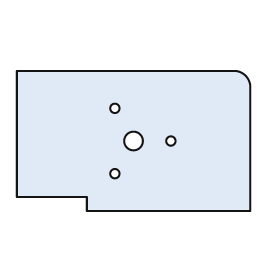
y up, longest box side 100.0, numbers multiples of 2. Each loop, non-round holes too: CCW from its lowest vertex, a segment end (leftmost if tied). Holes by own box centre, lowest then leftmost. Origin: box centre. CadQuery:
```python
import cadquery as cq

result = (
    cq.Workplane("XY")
    .moveTo(-20.0, -30.0)
    .lineTo(50.0, -30.0)
    .lineTo(50.0, 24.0)
    .threePointArc((48.0, 28.0), (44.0, 30.0))
    .lineTo(-50.0, 30.0)
    .lineTo(-50.0, -24.0)
    .lineTo(-20.0, -24.0)
    .close()
    .moveTo(-8.0, -14.0)
    .circle(2.0)
    .moveTo(0.0, 0.0)
    .circle(4.0)
    .moveTo(16.0, 0.0)
    .circle(2.0)
    .moveTo(-8.0, 14.0)
    .circle(2.0)
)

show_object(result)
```